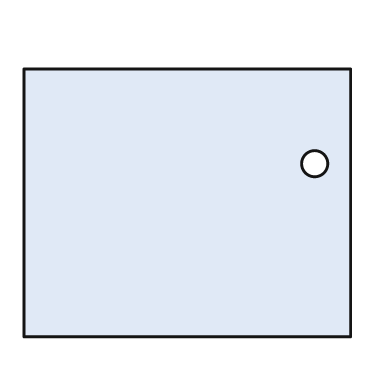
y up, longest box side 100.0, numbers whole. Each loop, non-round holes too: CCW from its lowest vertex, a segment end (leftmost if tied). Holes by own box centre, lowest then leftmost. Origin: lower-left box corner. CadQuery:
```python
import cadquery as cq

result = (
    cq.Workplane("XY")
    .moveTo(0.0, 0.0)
    .lineTo(100.0, 0.0)
    .lineTo(100.0, 82.0)
    .lineTo(0.0, 82.0)
    .close()
    .moveTo(89.0, 53.0)
    .circle(4.0)
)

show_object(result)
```